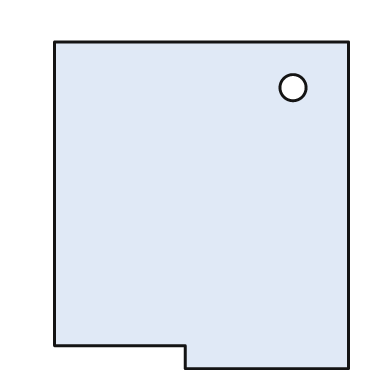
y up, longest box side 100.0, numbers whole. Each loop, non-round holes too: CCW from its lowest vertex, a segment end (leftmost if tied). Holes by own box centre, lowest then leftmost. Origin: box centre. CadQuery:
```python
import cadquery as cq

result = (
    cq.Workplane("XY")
    .moveTo(-5.0, -50.0)
    .lineTo(45.0, -50.0)
    .lineTo(45.0, 50.0)
    .lineTo(-45.0, 50.0)
    .lineTo(-45.0, -43.0)
    .lineTo(-5.0, -43.0)
    .close()
    .moveTo(28.0, 36.0)
    .circle(4.0)
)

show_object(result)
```